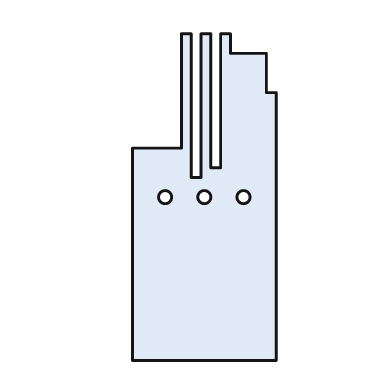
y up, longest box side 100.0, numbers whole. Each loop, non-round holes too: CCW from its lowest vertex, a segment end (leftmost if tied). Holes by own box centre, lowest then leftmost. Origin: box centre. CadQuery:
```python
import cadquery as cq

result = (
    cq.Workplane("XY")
    .moveTo(-22.0, -50.0)
    .lineTo(22.0, -50.0)
    .lineTo(22.0, 32.0)
    .lineTo(19.0, 32.0)
    .lineTo(19.0, 44.0)
    .lineTo(8.0, 44.0)
    .lineTo(8.0, 50.0)
    .lineTo(5.0, 50.0)
    .lineTo(5.0, 9.0)
    .lineTo(2.0, 9.0)
    .lineTo(2.0, 50.0)
    .lineTo(-1.0, 50.0)
    .lineTo(-1.0, 6.0)
    .lineTo(-4.0, 6.0)
    .lineTo(-4.0, 50.0)
    .lineTo(-7.0, 50.0)
    .lineTo(-7.0, 15.0)
    .lineTo(-22.0, 15.0)
    .close()
    .moveTo(-12.0, 0.0)
    .circle(2.0)
    .moveTo(0.0, 0.0)
    .circle(2.0)
    .moveTo(12.0, 0.0)
    .circle(2.0)
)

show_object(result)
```